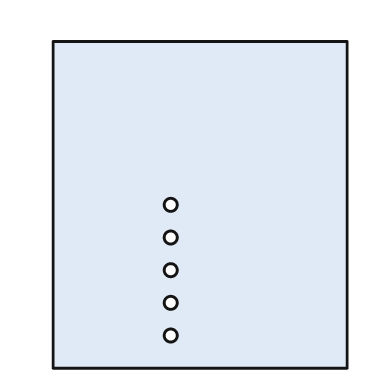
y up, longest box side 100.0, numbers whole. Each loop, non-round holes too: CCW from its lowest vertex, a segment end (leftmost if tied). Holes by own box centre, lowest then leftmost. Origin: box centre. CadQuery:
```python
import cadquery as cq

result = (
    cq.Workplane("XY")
    .moveTo(-45.0, -50.0)
    .lineTo(45.0, -50.0)
    .lineTo(45.0, 50.0)
    .lineTo(-45.0, 50.0)
    .close()
    .moveTo(-9.0, -40.0)
    .circle(2.0)
    .moveTo(-9.0, -30.0)
    .circle(2.0)
    .moveTo(-9.0, -20.0)
    .circle(2.0)
    .moveTo(-9.0, -10.0)
    .circle(2.0)
    .moveTo(-9.0, 0.0)
    .circle(2.0)
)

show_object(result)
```